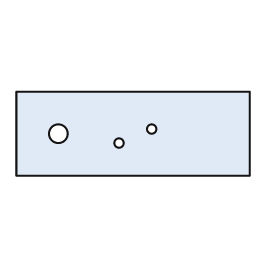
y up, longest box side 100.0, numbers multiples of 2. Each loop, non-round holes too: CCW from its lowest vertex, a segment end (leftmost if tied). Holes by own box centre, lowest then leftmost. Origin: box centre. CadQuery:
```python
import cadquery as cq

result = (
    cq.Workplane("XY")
    .moveTo(-50.0, -18.0)
    .lineTo(50.0, -18.0)
    .lineTo(50.0, 18.0)
    .lineTo(-50.0, 18.0)
    .close()
    .moveTo(-6.0, -4.0)
    .circle(2.0)
    .moveTo(-32.0, 0.0)
    .circle(4.0)
    .moveTo(8.0, 2.0)
    .circle(2.0)
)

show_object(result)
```